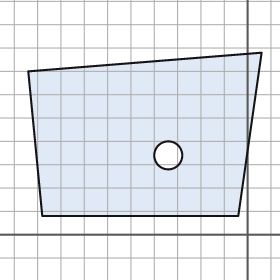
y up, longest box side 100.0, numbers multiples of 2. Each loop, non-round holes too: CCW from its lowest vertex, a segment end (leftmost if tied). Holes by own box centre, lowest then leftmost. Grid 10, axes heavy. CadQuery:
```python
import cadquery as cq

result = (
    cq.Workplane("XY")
    .moveTo(-88.0, 8.0)
    .lineTo(-4.0, 8.0)
    .lineTo(6.0, 78.0)
    .lineTo(-94.0, 70.0)
    .close()
    .moveTo(-34.0, 34.0)
    .circle(6.0)
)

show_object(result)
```